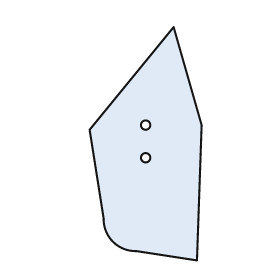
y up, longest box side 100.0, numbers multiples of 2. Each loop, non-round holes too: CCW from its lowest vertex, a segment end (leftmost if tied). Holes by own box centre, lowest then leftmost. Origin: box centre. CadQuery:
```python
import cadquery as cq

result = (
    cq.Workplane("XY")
    .moveTo(22.0, -50.0)
    .lineTo(24.0, 8.0)
    .lineTo(12.0, 50.0)
    .lineTo(-24.0, 6.0)
    .lineTo(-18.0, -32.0)
    .threePointArc((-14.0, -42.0), (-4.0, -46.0))
    .close()
    .moveTo(0.0, -6.0)
    .circle(2.0)
    .moveTo(0.0, 8.0)
    .circle(2.0)
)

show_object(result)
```